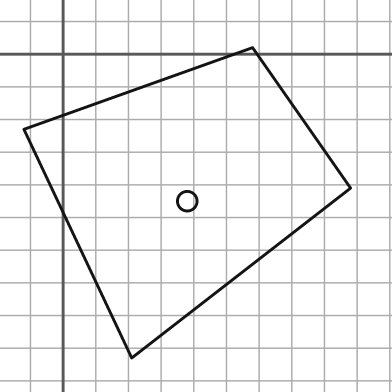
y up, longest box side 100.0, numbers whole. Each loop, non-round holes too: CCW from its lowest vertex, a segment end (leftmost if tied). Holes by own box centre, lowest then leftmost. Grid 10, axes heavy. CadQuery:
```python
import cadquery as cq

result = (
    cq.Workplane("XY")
    .moveTo(21.0, -93.0)
    .lineTo(88.0, -41.0)
    .lineTo(58.0, 2.0)
    .lineTo(-12.0, -23.0)
    .close()
    .moveTo(38.0, -45.0)
    .circle(3.0)
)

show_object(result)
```